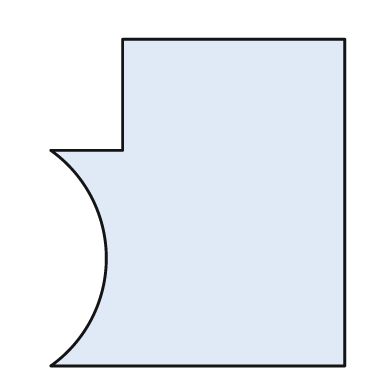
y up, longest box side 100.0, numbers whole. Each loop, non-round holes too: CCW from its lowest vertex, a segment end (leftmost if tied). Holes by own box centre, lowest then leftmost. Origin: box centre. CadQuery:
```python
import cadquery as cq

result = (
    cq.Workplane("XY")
    .moveTo(-45.0, -50.0)
    .lineTo(45.0, -50.0)
    .lineTo(45.0, 50.0)
    .lineTo(-23.0, 50.0)
    .lineTo(-23.0, 16.0)
    .lineTo(-45.0, 16.0)
    .threePointArc((-28.0, -17.0), (-45.0, -50.0))
    .close()
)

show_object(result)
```